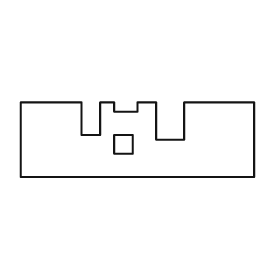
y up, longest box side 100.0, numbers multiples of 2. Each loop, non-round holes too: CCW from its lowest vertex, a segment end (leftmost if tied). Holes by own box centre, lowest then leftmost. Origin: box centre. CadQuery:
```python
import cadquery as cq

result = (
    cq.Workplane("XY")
    .moveTo(-50.0, -16.0)
    .lineTo(50.0, -16.0)
    .lineTo(50.0, 16.0)
    .lineTo(20.0, 16.0)
    .lineTo(20.0, 0.0)
    .lineTo(8.0, 0.0)
    .lineTo(8.0, 16.0)
    .lineTo(0.0, 16.0)
    .lineTo(0.0, 12.0)
    .lineTo(-10.0, 12.0)
    .lineTo(-10.0, 16.0)
    .lineTo(-16.0, 16.0)
    .lineTo(-16.0, 2.0)
    .lineTo(-24.0, 2.0)
    .lineTo(-24.0, 16.0)
    .lineTo(-50.0, 16.0)
    .close()
    .moveTo(-10.0, -6.0)
    .lineTo(-2.0, -6.0)
    .lineTo(-2.0, 2.0)
    .lineTo(-10.0, 2.0)
    .close()
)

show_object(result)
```